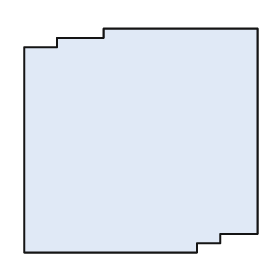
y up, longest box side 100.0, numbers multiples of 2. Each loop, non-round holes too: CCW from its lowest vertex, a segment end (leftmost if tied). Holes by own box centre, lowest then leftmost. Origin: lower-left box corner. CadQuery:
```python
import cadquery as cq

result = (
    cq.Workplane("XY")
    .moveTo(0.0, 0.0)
    .lineTo(74.0, 0.0)
    .lineTo(74.0, 4.0)
    .lineTo(84.0, 4.0)
    .lineTo(84.0, 8.0)
    .lineTo(100.0, 8.0)
    .lineTo(100.0, 96.0)
    .lineTo(34.0, 96.0)
    .lineTo(34.0, 92.0)
    .lineTo(14.0, 92.0)
    .lineTo(14.0, 88.0)
    .lineTo(0.0, 88.0)
    .close()
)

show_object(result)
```